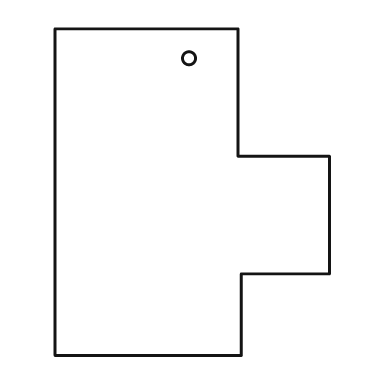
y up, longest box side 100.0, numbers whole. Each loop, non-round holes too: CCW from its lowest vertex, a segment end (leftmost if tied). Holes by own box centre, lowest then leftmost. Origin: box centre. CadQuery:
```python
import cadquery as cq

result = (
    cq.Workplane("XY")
    .moveTo(-42.0, -50.0)
    .lineTo(15.0, -50.0)
    .lineTo(15.0, -25.0)
    .lineTo(42.0, -25.0)
    .lineTo(42.0, 11.0)
    .lineTo(14.0, 11.0)
    .lineTo(14.0, 50.0)
    .lineTo(-42.0, 50.0)
    .close()
    .moveTo(-1.0, 41.0)
    .circle(2.0)
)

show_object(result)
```